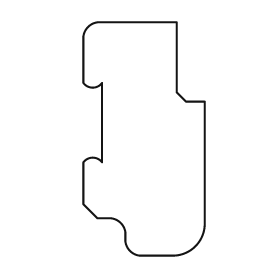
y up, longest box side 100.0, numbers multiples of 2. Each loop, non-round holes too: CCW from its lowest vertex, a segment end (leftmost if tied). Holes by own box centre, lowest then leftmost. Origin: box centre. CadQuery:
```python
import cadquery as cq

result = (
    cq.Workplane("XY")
    .moveTo(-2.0, -50.0)
    .lineTo(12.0, -50.0)
    .threePointArc((22.0, -46.0), (26.0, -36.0))
    .lineTo(26.0, 16.0)
    .lineTo(18.0, 16.0)
    .lineTo(14.0, 20.0)
    .lineTo(14.0, 50.0)
    .lineTo(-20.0, 50.0)
    .threePointArc((-24.0, 48.0), (-26.0, 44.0))
    .lineTo(-26.0, 24.0)
    .threePointArc((-22.0, 22.0), (-18.0, 24.0))
    .lineTo(-18.0, -10.0)
    .threePointArc((-22.0, -8.0), (-26.0, -10.0))
    .lineTo(-26.0, -28.0)
    .lineTo(-20.0, -34.0)
    .lineTo(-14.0, -34.0)
    .threePointArc((-10.0, -36.0), (-8.0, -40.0))
    .lineTo(-8.0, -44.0)
    .threePointArc((-6.0, -48.0), (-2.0, -50.0))
    .close()
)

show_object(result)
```